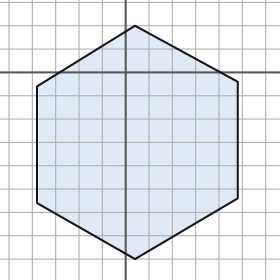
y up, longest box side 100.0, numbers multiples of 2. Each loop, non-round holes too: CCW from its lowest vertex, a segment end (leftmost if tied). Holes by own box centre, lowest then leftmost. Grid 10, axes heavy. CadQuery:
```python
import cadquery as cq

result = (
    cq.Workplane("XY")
    .moveTo(4.0, -80.0)
    .lineTo(48.0, -54.0)
    .lineTo(48.0, -4.0)
    .lineTo(4.0, 20.0)
    .lineTo(-38.0, -6.0)
    .lineTo(-38.0, -56.0)
    .close()
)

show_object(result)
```